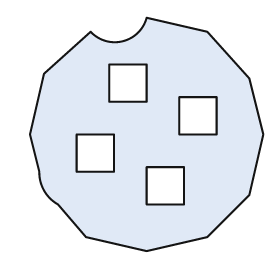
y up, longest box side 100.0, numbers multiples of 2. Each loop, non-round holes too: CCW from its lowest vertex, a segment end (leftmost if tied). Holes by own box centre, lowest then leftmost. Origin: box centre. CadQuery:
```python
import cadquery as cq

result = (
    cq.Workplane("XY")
    .moveTo(0.0, -50.0)
    .lineTo(26.0, -44.0)
    .lineTo(44.0, -26.0)
    .lineTo(50.0, 0.0)
    .lineTo(44.0, 24.0)
    .lineTo(26.0, 44.0)
    .lineTo(0.0, 50.0)
    .threePointArc((-10.0, 40.0), (-24.0, 44.0))
    .lineTo(-44.0, 26.0)
    .lineTo(-50.0, 0.0)
    .lineTo(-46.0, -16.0)
    .threePointArc((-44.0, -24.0), (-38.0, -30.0))
    .lineTo(-26.0, -44.0)
    .close()
    .moveTo(0.0, -30.0)
    .lineTo(16.0, -30.0)
    .lineTo(16.0, -14.0)
    .lineTo(0.0, -14.0)
    .close()
    .moveTo(-30.0, -16.0)
    .lineTo(-14.0, -16.0)
    .lineTo(-14.0, 0.0)
    .lineTo(-30.0, 0.0)
    .close()
    .moveTo(14.0, 0.0)
    .lineTo(30.0, 0.0)
    .lineTo(30.0, 16.0)
    .lineTo(14.0, 16.0)
    .close()
    .moveTo(-16.0, 14.0)
    .lineTo(0.0, 14.0)
    .lineTo(0.0, 30.0)
    .lineTo(-16.0, 30.0)
    .close()
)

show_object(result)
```